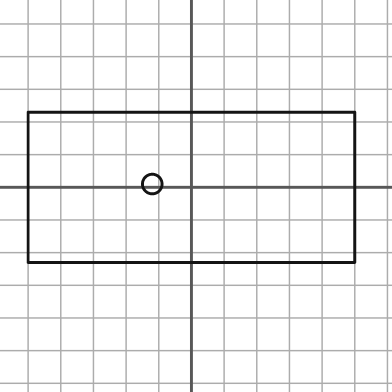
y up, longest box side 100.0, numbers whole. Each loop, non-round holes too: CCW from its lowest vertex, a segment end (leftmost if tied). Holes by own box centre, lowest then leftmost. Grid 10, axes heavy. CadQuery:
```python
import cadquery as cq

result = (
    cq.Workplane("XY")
    .moveTo(-50.0, -23.0)
    .lineTo(50.0, -23.0)
    .lineTo(50.0, 23.0)
    .lineTo(-50.0, 23.0)
    .close()
    .moveTo(-12.0, 1.0)
    .circle(3.0)
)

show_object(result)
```